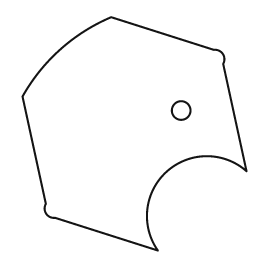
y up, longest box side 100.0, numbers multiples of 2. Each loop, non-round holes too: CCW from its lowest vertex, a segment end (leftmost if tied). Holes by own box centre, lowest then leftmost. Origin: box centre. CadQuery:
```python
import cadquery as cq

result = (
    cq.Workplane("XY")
    .moveTo(10.0, -50.0)
    .threePointArc((14.0, -16.0), (48.0, -16.0))
    .lineTo(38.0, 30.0)
    .threePointArc((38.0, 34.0), (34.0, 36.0))
    .lineTo(-10.0, 50.0)
    .threePointArc((-32.0, 36.0), (-48.0, 16.0))
    .lineTo(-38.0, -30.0)
    .threePointArc((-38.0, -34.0), (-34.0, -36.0))
    .close()
    .moveTo(20.0, 10.0)
    .circle(4.0)
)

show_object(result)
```